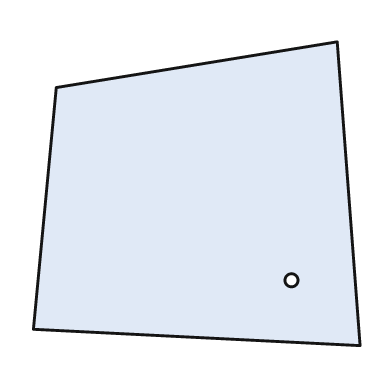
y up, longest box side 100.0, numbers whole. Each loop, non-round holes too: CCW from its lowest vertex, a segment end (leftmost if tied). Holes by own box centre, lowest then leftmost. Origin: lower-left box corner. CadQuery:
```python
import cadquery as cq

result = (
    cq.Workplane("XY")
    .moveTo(100.0, 0.0)
    .lineTo(93.0, 93.0)
    .lineTo(7.0, 79.0)
    .lineTo(0.0, 5.0)
    .close()
    .moveTo(79.0, 20.0)
    .circle(2.0)
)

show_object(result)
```